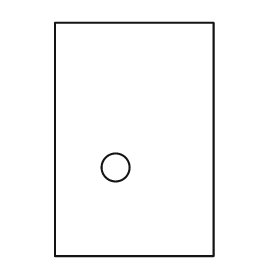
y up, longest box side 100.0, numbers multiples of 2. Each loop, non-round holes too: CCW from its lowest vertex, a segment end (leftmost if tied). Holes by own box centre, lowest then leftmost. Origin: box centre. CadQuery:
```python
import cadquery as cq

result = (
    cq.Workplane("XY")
    .moveTo(-34.0, -50.0)
    .lineTo(34.0, -50.0)
    .lineTo(34.0, 50.0)
    .lineTo(-34.0, 50.0)
    .close()
    .moveTo(-8.0, -12.0)
    .circle(6.0)
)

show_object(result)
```